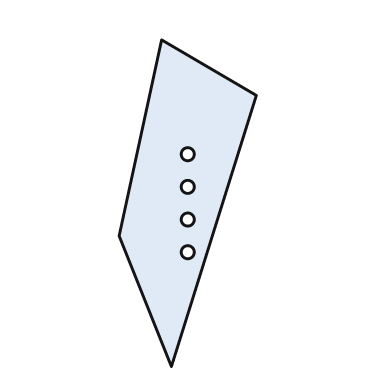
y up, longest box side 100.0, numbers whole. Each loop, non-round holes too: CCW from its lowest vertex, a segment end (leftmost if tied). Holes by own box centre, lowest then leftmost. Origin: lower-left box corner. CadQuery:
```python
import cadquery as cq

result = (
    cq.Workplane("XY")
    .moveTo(16.0, 0.0)
    .lineTo(42.0, 83.0)
    .lineTo(13.0, 100.0)
    .lineTo(0.0, 40.0)
    .close()
    .moveTo(21.0, 35.0)
    .circle(2.0)
    .moveTo(21.0, 45.0)
    .circle(2.0)
    .moveTo(21.0, 55.0)
    .circle(2.0)
    .moveTo(21.0, 65.0)
    .circle(2.0)
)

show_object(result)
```